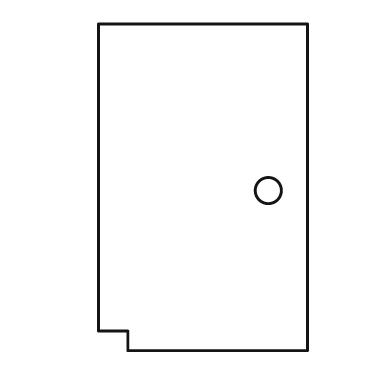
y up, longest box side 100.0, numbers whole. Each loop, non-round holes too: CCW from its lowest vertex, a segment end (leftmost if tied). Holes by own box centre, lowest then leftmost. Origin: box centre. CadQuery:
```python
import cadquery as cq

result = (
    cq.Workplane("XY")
    .moveTo(-23.0, -50.0)
    .lineTo(32.0, -50.0)
    .lineTo(32.0, 50.0)
    .lineTo(-32.0, 50.0)
    .lineTo(-32.0, -44.0)
    .lineTo(-23.0, -44.0)
    .close()
    .moveTo(20.0, -1.0)
    .circle(4.0)
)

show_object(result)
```